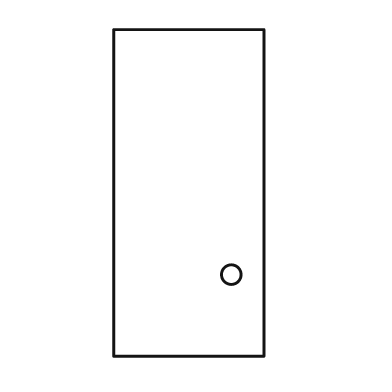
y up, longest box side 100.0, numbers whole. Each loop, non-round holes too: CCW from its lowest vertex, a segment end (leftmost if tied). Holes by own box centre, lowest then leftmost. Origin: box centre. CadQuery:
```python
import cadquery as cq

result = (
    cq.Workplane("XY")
    .moveTo(-23.0, -50.0)
    .lineTo(23.0, -50.0)
    .lineTo(23.0, 50.0)
    .lineTo(-23.0, 50.0)
    .close()
    .moveTo(13.0, -25.0)
    .circle(3.0)
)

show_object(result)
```